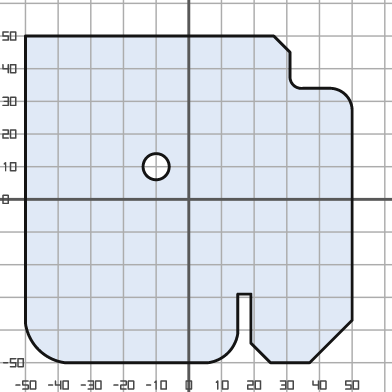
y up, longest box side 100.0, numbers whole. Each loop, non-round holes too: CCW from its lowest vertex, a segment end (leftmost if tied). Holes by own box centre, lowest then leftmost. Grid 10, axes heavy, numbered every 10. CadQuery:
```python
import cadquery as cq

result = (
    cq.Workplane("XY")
    .moveTo(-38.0, -50.0)
    .lineTo(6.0, -50.0)
    .threePointArc((12.0, -47.0), (15.0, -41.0))
    .lineTo(15.0, -29.0)
    .lineTo(19.0, -29.0)
    .lineTo(19.0, -44.0)
    .lineTo(25.0, -50.0)
    .lineTo(37.0, -50.0)
    .lineTo(50.0, -37.0)
    .lineTo(50.0, 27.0)
    .threePointArc((48.0, 32.0), (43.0, 34.0))
    .lineTo(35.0, 34.0)
    .threePointArc((32.0, 35.0), (31.0, 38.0))
    .lineTo(31.0, 45.0)
    .lineTo(26.0, 50.0)
    .lineTo(-50.0, 50.0)
    .lineTo(-50.0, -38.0)
    .threePointArc((-46.0, -46.0), (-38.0, -50.0))
    .close()
    .moveTo(-10.0, 10.0)
    .circle(4.0)
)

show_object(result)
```